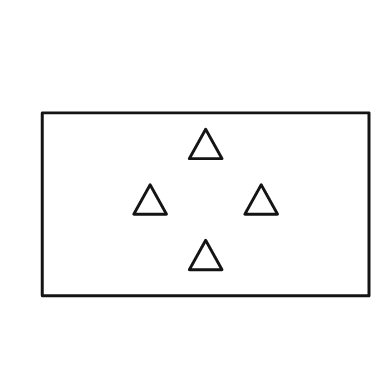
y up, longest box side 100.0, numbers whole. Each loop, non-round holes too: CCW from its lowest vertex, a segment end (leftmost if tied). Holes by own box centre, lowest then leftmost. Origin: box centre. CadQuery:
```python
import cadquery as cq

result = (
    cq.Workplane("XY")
    .moveTo(-50.0, -28.0)
    .lineTo(50.0, -28.0)
    .lineTo(50.0, 28.0)
    .lineTo(-50.0, 28.0)
    .close()
    .moveTo(-5.0, -20.0)
    .lineTo(5.0, -20.0)
    .lineTo(0.0, -11.0)
    .close()
    .moveTo(-22.0, -3.0)
    .lineTo(-12.0, -3.0)
    .lineTo(-17.0, 6.0)
    .close()
    .moveTo(12.0, -3.0)
    .lineTo(22.0, -3.0)
    .lineTo(17.0, 6.0)
    .close()
    .moveTo(-5.0, 14.0)
    .lineTo(5.0, 14.0)
    .lineTo(0.0, 23.0)
    .close()
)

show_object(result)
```